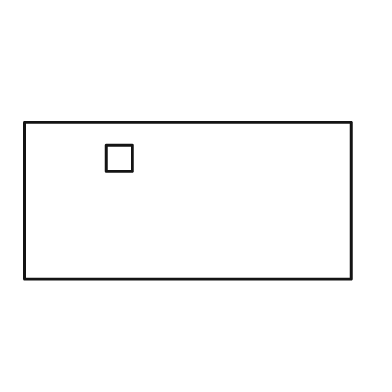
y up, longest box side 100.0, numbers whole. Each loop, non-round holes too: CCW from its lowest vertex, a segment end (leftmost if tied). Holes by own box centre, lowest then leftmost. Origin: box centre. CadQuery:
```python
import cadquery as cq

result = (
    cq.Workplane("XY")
    .moveTo(-50.0, -24.0)
    .lineTo(50.0, -24.0)
    .lineTo(50.0, 24.0)
    .lineTo(-50.0, 24.0)
    .close()
    .moveTo(-25.0, 9.0)
    .lineTo(-17.0, 9.0)
    .lineTo(-17.0, 17.0)
    .lineTo(-25.0, 17.0)
    .close()
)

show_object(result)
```